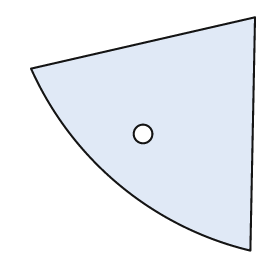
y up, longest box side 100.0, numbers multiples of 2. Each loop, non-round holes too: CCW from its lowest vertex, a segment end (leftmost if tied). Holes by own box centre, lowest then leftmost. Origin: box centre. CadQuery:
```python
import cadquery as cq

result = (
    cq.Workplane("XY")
    .moveTo(46.0, -50.0)
    .lineTo(48.0, 50.0)
    .lineTo(-48.0, 28.0)
    .threePointArc((-10.0, -22.0), (46.0, -50.0))
    .close()
    .moveTo(0.0, 0.0)
    .circle(4.0)
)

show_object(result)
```